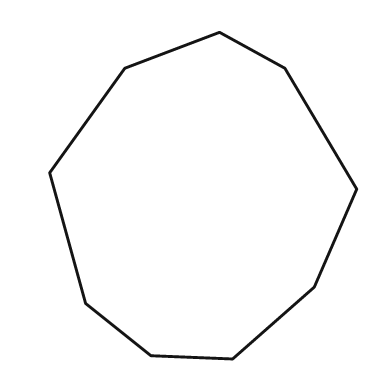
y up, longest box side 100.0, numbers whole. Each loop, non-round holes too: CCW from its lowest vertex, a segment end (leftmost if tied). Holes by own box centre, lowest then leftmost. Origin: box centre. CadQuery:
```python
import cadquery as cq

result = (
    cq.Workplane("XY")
    .moveTo(9.0, -50.0)
    .lineTo(34.0, -28.0)
    .lineTo(47.0, 2.0)
    .lineTo(25.0, 39.0)
    .lineTo(5.0, 50.0)
    .lineTo(-24.0, 39.0)
    .lineTo(-47.0, 7.0)
    .lineTo(-36.0, -33.0)
    .lineTo(-16.0, -49.0)
    .close()
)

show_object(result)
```